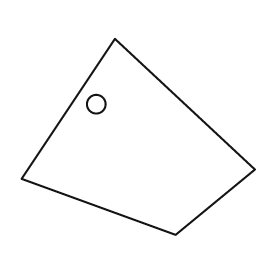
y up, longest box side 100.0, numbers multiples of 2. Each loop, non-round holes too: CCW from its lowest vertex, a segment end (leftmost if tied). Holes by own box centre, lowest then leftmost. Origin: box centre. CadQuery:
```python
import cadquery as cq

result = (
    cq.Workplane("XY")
    .moveTo(16.0, -42.0)
    .lineTo(50.0, -14.0)
    .lineTo(-10.0, 42.0)
    .lineTo(-50.0, -18.0)
    .close()
    .moveTo(-18.0, 14.0)
    .circle(4.0)
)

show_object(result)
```